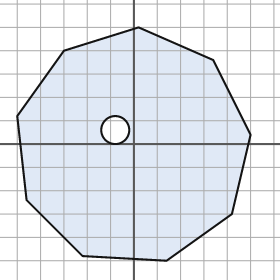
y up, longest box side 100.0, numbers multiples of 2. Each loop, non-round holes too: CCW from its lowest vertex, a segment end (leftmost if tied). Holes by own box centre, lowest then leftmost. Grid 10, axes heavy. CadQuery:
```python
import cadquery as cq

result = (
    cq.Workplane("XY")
    .moveTo(14.0, -50.0)
    .lineTo(42.0, -30.0)
    .lineTo(50.0, 4.0)
    .lineTo(34.0, 36.0)
    .lineTo(2.0, 50.0)
    .lineTo(-30.0, 40.0)
    .lineTo(-50.0, 12.0)
    .lineTo(-46.0, -24.0)
    .lineTo(-22.0, -48.0)
    .close()
    .moveTo(-8.0, 6.0)
    .circle(6.0)
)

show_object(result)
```